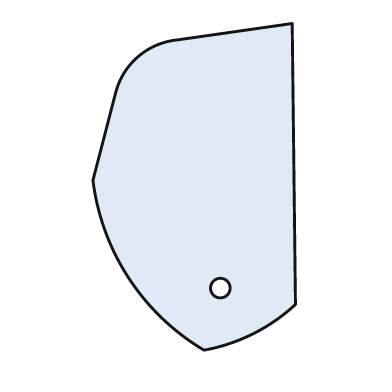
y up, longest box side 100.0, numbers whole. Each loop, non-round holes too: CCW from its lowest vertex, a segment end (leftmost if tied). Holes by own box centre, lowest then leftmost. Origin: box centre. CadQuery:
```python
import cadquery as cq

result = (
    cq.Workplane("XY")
    .moveTo(3.0, -50.0)
    .threePointArc((18.0, -45.0), (31.0, -36.0))
    .lineTo(30.0, 50.0)
    .lineTo(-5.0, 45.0)
    .threePointArc((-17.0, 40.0), (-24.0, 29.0))
    .lineTo(-31.0, 2.0)
    .threePointArc((-20.0, -28.0), (3.0, -50.0))
    .close()
    .moveTo(8.0, -31.0)
    .circle(3.0)
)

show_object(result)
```